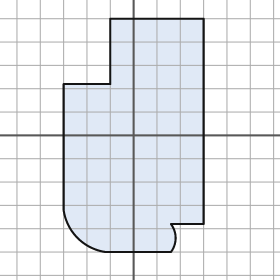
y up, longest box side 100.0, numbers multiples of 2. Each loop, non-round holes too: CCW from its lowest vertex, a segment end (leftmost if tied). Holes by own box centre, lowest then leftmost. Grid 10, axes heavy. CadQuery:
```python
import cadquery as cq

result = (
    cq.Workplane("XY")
    .moveTo(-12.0, -50.0)
    .lineTo(16.0, -50.0)
    .threePointArc((18.0, -44.0), (16.0, -38.0))
    .lineTo(30.0, -38.0)
    .lineTo(30.0, 50.0)
    .lineTo(-10.0, 50.0)
    .lineTo(-10.0, 22.0)
    .lineTo(-30.0, 22.0)
    .lineTo(-30.0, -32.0)
    .threePointArc((-24.0, -44.0), (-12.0, -50.0))
    .close()
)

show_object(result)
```